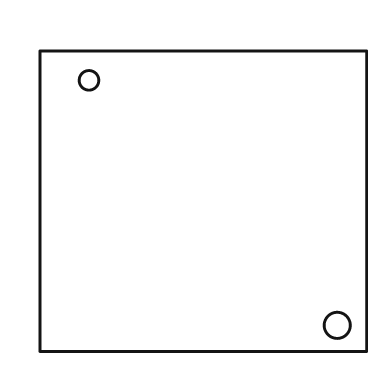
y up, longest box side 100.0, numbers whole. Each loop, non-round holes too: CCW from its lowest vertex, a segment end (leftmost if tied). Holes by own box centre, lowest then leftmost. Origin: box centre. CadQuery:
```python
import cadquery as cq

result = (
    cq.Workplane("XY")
    .moveTo(-50.0, -46.0)
    .lineTo(50.0, -46.0)
    .lineTo(50.0, 46.0)
    .lineTo(-50.0, 46.0)
    .close()
    .moveTo(41.0, -38.0)
    .circle(4.0)
    .moveTo(-35.0, 37.0)
    .circle(3.0)
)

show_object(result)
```